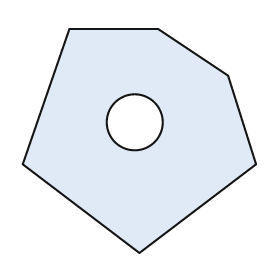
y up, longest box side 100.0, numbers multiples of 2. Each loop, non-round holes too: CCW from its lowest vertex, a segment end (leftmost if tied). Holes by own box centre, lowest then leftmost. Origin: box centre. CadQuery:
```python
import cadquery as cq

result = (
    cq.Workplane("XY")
    .moveTo(0.0, -48.0)
    .lineTo(50.0, -10.0)
    .lineTo(38.0, 28.0)
    .lineTo(8.0, 48.0)
    .lineTo(-30.0, 48.0)
    .lineTo(-50.0, -10.0)
    .close()
    .moveTo(-2.0, 8.0)
    .circle(12.0)
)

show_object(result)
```